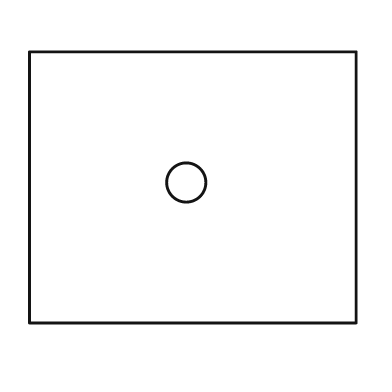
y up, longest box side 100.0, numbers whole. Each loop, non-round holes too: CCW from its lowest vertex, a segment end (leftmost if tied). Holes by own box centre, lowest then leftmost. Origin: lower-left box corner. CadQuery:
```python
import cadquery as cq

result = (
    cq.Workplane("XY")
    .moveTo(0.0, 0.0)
    .lineTo(100.0, 0.0)
    .lineTo(100.0, 83.0)
    .lineTo(0.0, 83.0)
    .close()
    .moveTo(48.0, 43.0)
    .circle(6.0)
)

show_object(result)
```